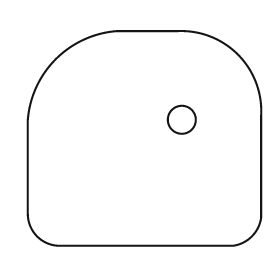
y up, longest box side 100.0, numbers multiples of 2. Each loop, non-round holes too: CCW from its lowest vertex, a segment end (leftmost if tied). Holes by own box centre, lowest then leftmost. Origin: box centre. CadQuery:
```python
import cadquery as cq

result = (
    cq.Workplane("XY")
    .moveTo(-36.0, -46.0)
    .lineTo(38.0, -46.0)
    .threePointArc((46.0, -42.0), (50.0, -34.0))
    .lineTo(50.0, 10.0)
    .threePointArc((40.0, 36.0), (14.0, 46.0))
    .lineTo(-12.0, 46.0)
    .threePointArc((-38.0, 34.0), (-50.0, 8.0))
    .lineTo(-50.0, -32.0)
    .threePointArc((-46.0, -42.0), (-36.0, -46.0))
    .close()
    .moveTo(16.0, 8.0)
    .circle(6.0)
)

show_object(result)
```